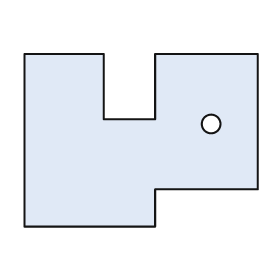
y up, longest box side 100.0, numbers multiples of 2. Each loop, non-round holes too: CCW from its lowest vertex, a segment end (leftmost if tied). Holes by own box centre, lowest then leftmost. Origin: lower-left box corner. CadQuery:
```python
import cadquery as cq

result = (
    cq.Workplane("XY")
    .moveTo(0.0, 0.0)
    .lineTo(56.0, 0.0)
    .lineTo(56.0, 16.0)
    .lineTo(100.0, 16.0)
    .lineTo(100.0, 74.0)
    .lineTo(56.0, 74.0)
    .lineTo(56.0, 46.0)
    .lineTo(34.0, 46.0)
    .lineTo(34.0, 74.0)
    .lineTo(0.0, 74.0)
    .close()
    .moveTo(80.0, 44.0)
    .circle(4.0)
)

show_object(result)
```